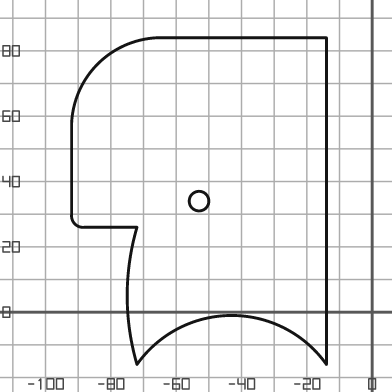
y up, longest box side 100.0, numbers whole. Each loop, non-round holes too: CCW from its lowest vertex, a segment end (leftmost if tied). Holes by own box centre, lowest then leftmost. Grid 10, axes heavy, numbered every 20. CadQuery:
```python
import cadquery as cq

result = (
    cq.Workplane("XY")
    .moveTo(-72.0, -16.0)
    .threePointArc((-43.0, -1.0), (-14.0, -16.0))
    .lineTo(-14.0, 84.0)
    .lineTo(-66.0, 84.0)
    .threePointArc((-84.0, 76.0), (-92.0, 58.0))
    .lineTo(-92.0, 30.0)
    .threePointArc((-91.0, 27.0), (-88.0, 26.0))
    .lineTo(-72.0, 26.0)
    .threePointArc((-75.0, 5.0), (-72.0, -16.0))
    .close()
    .moveTo(-53.0, 34.0)
    .circle(3.0)
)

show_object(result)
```